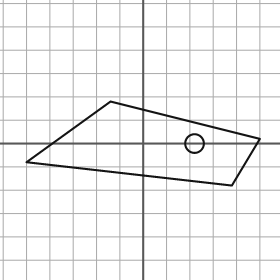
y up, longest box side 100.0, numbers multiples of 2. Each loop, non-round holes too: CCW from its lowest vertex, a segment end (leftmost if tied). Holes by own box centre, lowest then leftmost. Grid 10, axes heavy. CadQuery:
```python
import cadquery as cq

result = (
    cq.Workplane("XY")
    .moveTo(38.0, -18.0)
    .lineTo(50.0, 2.0)
    .lineTo(-14.0, 18.0)
    .lineTo(-50.0, -8.0)
    .close()
    .moveTo(22.0, 0.0)
    .circle(4.0)
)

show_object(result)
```